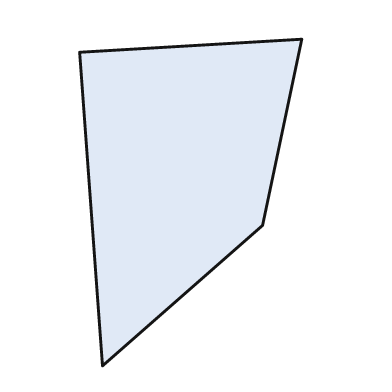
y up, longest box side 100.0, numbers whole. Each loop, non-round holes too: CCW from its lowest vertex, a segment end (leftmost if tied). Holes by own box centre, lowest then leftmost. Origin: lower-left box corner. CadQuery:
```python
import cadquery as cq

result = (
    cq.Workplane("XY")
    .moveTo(7.0, 0.0)
    .lineTo(56.0, 43.0)
    .lineTo(68.0, 100.0)
    .lineTo(0.0, 96.0)
    .close()
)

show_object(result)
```